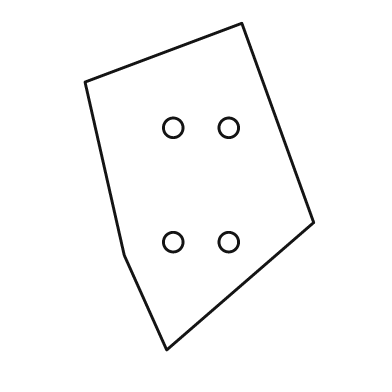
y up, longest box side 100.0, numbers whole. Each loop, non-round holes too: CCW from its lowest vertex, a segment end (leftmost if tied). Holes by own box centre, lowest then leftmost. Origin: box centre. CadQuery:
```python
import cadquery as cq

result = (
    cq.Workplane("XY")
    .moveTo(-10.0, -50.0)
    .lineTo(35.0, -11.0)
    .lineTo(13.0, 50.0)
    .lineTo(-35.0, 32.0)
    .lineTo(-23.0, -21.0)
    .close()
    .moveTo(-8.0, -17.0)
    .circle(3.0)
    .moveTo(9.0, -17.0)
    .circle(3.0)
    .moveTo(-8.0, 18.0)
    .circle(3.0)
    .moveTo(9.0, 18.0)
    .circle(3.0)
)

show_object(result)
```